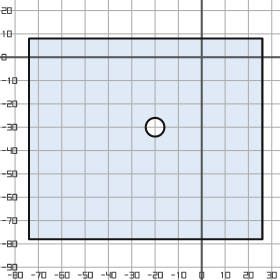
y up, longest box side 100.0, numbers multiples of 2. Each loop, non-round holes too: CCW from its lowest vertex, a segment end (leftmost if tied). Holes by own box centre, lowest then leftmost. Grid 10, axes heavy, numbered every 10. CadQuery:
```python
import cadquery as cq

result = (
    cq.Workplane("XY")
    .moveTo(-74.0, -78.0)
    .lineTo(26.0, -78.0)
    .lineTo(26.0, 8.0)
    .lineTo(-74.0, 8.0)
    .close()
    .moveTo(-20.0, -30.0)
    .circle(4.0)
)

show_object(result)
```